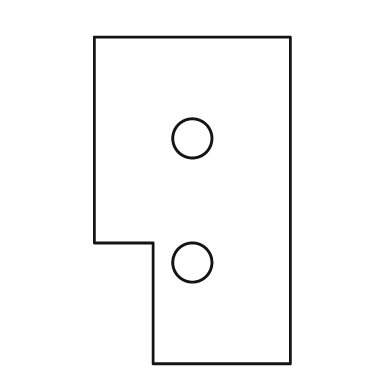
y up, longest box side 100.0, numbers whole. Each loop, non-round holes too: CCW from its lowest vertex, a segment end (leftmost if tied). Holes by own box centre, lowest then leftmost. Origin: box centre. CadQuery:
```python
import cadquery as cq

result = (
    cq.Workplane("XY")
    .moveTo(-12.0, -50.0)
    .lineTo(30.0, -50.0)
    .lineTo(30.0, 50.0)
    .lineTo(-30.0, 50.0)
    .lineTo(-30.0, -13.0)
    .lineTo(-12.0, -13.0)
    .close()
    .moveTo(0.0, -19.0)
    .circle(6.0)
    .moveTo(0.0, 19.0)
    .circle(6.0)
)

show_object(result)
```